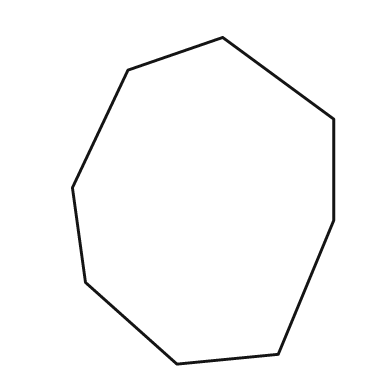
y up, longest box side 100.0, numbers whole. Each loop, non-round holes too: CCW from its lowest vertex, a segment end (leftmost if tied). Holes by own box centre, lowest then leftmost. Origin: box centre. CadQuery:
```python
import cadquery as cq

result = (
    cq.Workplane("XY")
    .moveTo(-8.0, -50.0)
    .lineTo(23.0, -47.0)
    .lineTo(40.0, -6.0)
    .lineTo(40.0, 25.0)
    .lineTo(6.0, 50.0)
    .lineTo(-23.0, 40.0)
    .lineTo(-40.0, 4.0)
    .lineTo(-36.0, -25.0)
    .close()
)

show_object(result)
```